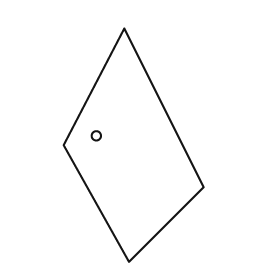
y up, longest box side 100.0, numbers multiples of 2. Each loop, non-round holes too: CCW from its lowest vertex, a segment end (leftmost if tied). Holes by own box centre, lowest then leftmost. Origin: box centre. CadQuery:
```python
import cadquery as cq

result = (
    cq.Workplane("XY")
    .moveTo(-2.0, -50.0)
    .lineTo(30.0, -18.0)
    .lineTo(-4.0, 50.0)
    .lineTo(-30.0, 0.0)
    .close()
    .moveTo(-16.0, 4.0)
    .circle(2.0)
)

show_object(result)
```